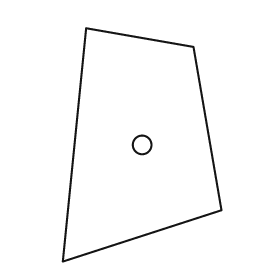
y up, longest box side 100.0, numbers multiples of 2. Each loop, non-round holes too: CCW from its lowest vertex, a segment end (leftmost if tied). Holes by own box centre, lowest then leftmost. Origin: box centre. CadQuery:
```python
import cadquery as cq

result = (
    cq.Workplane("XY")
    .moveTo(-34.0, -50.0)
    .lineTo(34.0, -28.0)
    .lineTo(22.0, 42.0)
    .lineTo(-24.0, 50.0)
    .close()
    .moveTo(0.0, 0.0)
    .circle(4.0)
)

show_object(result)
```